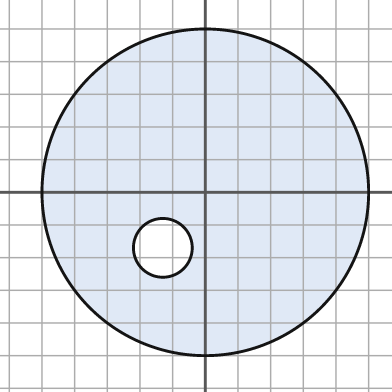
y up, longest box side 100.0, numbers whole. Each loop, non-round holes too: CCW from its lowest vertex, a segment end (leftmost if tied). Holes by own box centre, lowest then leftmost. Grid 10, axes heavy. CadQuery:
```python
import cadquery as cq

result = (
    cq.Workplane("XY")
    .moveTo(0.0, 0.0)
    .circle(50.0)
    .moveTo(-13.0, -17.0)
    .circle(9.0)
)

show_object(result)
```